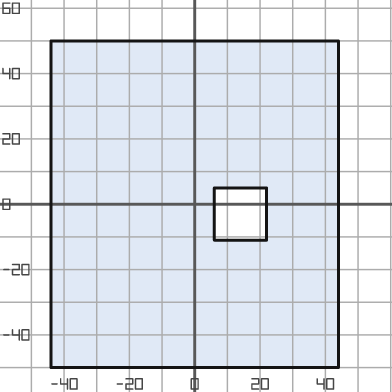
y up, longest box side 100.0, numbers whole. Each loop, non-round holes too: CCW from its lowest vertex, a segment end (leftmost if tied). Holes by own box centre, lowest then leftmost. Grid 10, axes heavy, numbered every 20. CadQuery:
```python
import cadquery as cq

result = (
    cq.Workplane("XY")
    .moveTo(-44.0, -50.0)
    .lineTo(44.0, -50.0)
    .lineTo(44.0, 50.0)
    .lineTo(-44.0, 50.0)
    .close()
    .moveTo(6.0, -11.0)
    .lineTo(22.0, -11.0)
    .lineTo(22.0, 5.0)
    .lineTo(6.0, 5.0)
    .close()
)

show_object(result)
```